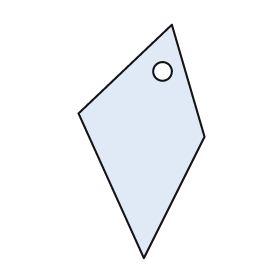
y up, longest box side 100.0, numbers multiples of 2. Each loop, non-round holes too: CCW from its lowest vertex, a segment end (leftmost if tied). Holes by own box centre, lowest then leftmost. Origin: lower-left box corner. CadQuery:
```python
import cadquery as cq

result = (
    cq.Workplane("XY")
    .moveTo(28.0, 0.0)
    .lineTo(54.0, 52.0)
    .lineTo(40.0, 100.0)
    .lineTo(0.0, 62.0)
    .close()
    .moveTo(36.0, 80.0)
    .circle(4.0)
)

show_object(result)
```